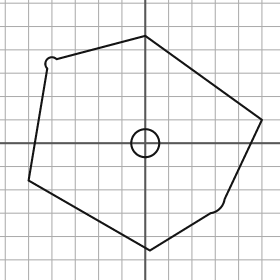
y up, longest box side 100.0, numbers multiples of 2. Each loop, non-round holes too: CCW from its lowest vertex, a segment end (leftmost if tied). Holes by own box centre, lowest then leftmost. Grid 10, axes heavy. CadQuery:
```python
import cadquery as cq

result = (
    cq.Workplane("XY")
    .moveTo(2.0, -46.0)
    .lineTo(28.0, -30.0)
    .threePointArc((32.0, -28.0), (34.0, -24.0))
    .lineTo(50.0, 10.0)
    .lineTo(0.0, 46.0)
    .lineTo(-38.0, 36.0)
    .threePointArc((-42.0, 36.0), (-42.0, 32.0))
    .lineTo(-50.0, -16.0)
    .close()
    .moveTo(0.0, 0.0)
    .circle(6.0)
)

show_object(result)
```